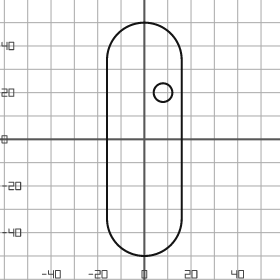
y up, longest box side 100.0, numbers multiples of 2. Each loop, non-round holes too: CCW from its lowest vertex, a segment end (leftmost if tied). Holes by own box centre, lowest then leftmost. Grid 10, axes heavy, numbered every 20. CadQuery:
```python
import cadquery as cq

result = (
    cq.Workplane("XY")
    .moveTo(-16.0, -34.0)
    .threePointArc((0.0, -50.0), (16.0, -34.0))
    .lineTo(16.0, 34.0)
    .threePointArc((0.0, 50.0), (-16.0, 34.0))
    .close()
    .moveTo(8.0, 20.0)
    .circle(4.0)
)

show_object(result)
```